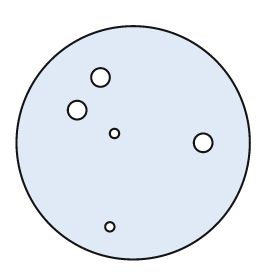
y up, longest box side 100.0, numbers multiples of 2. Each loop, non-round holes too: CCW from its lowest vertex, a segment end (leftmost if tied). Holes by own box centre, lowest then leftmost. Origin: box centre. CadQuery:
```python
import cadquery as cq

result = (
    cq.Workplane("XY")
    .moveTo(0.0, 0.0)
    .circle(50.0)
    .moveTo(-10.0, -36.0)
    .circle(2.0)
    .moveTo(30.0, 0.0)
    .circle(4.0)
    .moveTo(-8.0, 4.0)
    .circle(2.0)
    .moveTo(-24.0, 14.0)
    .circle(4.0)
    .moveTo(-14.0, 28.0)
    .circle(4.0)
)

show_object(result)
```